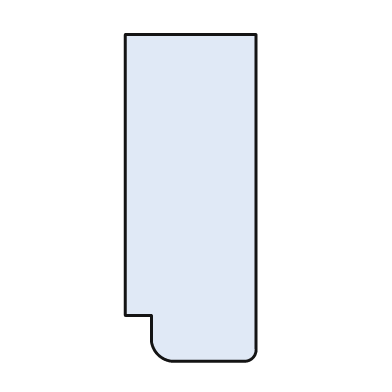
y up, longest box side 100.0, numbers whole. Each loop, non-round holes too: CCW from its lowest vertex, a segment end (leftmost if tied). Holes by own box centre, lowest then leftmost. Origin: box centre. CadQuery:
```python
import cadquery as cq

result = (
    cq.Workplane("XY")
    .moveTo(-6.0, -50.0)
    .lineTo(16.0, -50.0)
    .threePointArc((19.0, -49.0), (20.0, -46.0))
    .lineTo(20.0, 50.0)
    .lineTo(-20.0, 50.0)
    .lineTo(-20.0, -36.0)
    .lineTo(-12.0, -36.0)
    .lineTo(-12.0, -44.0)
    .threePointArc((-10.0, -48.0), (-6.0, -50.0))
    .close()
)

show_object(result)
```